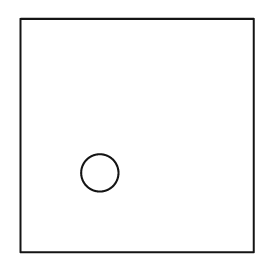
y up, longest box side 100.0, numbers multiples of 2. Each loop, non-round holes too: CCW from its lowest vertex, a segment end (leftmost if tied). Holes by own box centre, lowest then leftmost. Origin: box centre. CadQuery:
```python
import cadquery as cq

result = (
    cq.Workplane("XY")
    .moveTo(-50.0, -50.0)
    .lineTo(50.0, -50.0)
    .lineTo(50.0, 50.0)
    .lineTo(-50.0, 50.0)
    .close()
    .moveTo(-16.0, -16.0)
    .circle(8.0)
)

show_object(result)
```